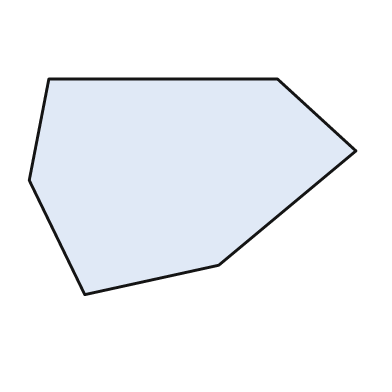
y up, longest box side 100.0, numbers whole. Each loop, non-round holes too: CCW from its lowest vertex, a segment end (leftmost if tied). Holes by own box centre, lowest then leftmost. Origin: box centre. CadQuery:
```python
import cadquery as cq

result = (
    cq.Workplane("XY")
    .moveTo(-33.0, -33.0)
    .lineTo(8.0, -24.0)
    .lineTo(50.0, 11.0)
    .lineTo(26.0, 33.0)
    .lineTo(-44.0, 33.0)
    .lineTo(-50.0, 2.0)
    .close()
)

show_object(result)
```